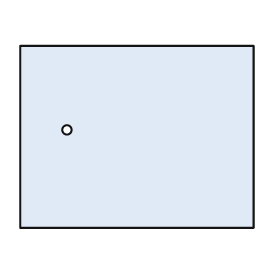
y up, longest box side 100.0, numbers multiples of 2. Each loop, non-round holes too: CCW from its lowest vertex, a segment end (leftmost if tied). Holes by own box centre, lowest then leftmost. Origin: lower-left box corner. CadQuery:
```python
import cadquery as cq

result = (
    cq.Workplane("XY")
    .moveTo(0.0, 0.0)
    .lineTo(100.0, 0.0)
    .lineTo(100.0, 78.0)
    .lineTo(0.0, 78.0)
    .close()
    .moveTo(20.0, 42.0)
    .circle(2.0)
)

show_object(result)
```